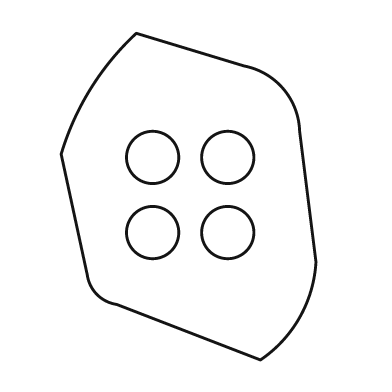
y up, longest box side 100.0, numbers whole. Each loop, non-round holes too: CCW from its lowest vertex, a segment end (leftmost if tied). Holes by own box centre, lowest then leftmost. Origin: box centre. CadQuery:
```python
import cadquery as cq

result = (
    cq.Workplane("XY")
    .moveTo(22.0, -50.0)
    .threePointArc((34.0, -37.0), (39.0, -20.0))
    .lineTo(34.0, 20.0)
    .threePointArc((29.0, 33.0), (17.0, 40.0))
    .lineTo(-16.0, 50.0)
    .threePointArc((-30.0, 33.0), (-39.0, 13.0))
    .lineTo(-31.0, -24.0)
    .threePointArc((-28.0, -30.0), (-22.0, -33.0))
    .close()
    .moveTo(-11.0, -11.0)
    .circle(8.0)
    .moveTo(12.0, -11.0)
    .circle(8.0)
    .moveTo(-11.0, 12.0)
    .circle(8.0)
    .moveTo(12.0, 12.0)
    .circle(8.0)
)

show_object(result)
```